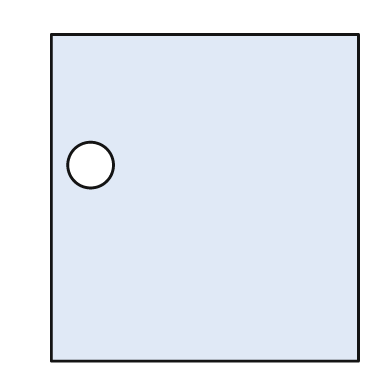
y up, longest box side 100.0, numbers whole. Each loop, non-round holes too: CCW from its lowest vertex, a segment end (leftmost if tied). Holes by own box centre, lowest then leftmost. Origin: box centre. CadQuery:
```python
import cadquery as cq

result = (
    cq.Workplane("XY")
    .moveTo(-47.0, -50.0)
    .lineTo(47.0, -50.0)
    .lineTo(47.0, 50.0)
    .lineTo(-47.0, 50.0)
    .close()
    .moveTo(-35.0, 10.0)
    .circle(7.0)
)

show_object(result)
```